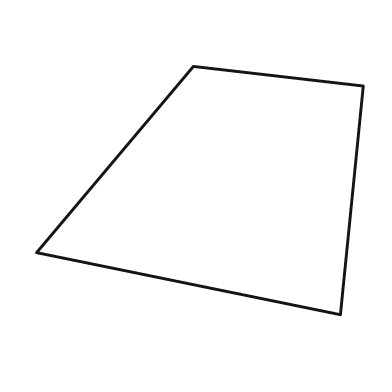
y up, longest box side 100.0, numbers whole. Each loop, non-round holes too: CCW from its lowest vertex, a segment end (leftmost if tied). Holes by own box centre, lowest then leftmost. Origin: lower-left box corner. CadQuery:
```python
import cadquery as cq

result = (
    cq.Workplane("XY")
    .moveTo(93.0, 0.0)
    .lineTo(100.0, 70.0)
    .lineTo(48.0, 76.0)
    .lineTo(0.0, 19.0)
    .close()
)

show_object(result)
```